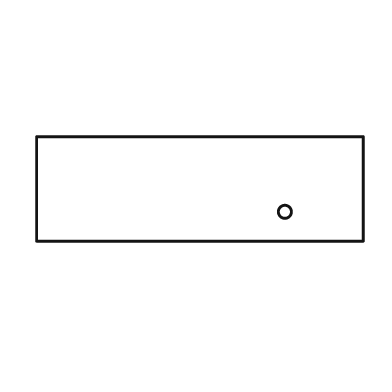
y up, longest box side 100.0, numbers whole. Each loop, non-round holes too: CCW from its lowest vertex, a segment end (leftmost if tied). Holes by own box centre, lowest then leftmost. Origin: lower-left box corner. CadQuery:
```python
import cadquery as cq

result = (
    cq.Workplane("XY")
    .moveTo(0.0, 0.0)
    .lineTo(100.0, 0.0)
    .lineTo(100.0, 32.0)
    .lineTo(0.0, 32.0)
    .close()
    .moveTo(76.0, 9.0)
    .circle(2.0)
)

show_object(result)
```